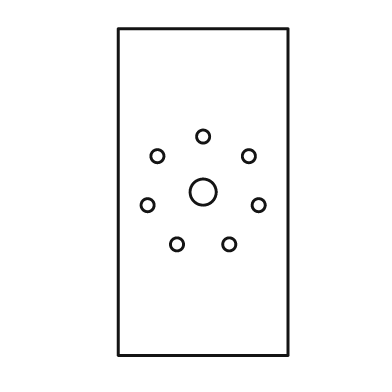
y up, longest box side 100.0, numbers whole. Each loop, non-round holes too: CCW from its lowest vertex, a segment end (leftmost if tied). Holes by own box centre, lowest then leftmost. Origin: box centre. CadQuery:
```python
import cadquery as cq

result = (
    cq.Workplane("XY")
    .moveTo(-26.0, -50.0)
    .lineTo(26.0, -50.0)
    .lineTo(26.0, 50.0)
    .lineTo(-26.0, 50.0)
    .close()
    .moveTo(-8.0, -16.0)
    .circle(2.0)
    .moveTo(8.0, -16.0)
    .circle(2.0)
    .moveTo(-17.0, -4.0)
    .circle(2.0)
    .moveTo(17.0, -4.0)
    .circle(2.0)
    .moveTo(0.0, 0.0)
    .circle(4.0)
    .moveTo(-14.0, 11.0)
    .circle(2.0)
    .moveTo(14.0, 11.0)
    .circle(2.0)
    .moveTo(0.0, 17.0)
    .circle(2.0)
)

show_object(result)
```